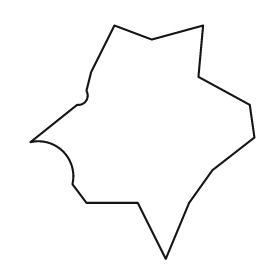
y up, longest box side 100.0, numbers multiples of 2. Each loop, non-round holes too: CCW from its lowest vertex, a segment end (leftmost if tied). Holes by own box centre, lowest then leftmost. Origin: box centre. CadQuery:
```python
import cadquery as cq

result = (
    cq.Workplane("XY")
    .moveTo(10.0, -50.0)
    .lineTo(20.0, -26.0)
    .lineTo(30.0, -12.0)
    .lineTo(48.0, 2.0)
    .lineTo(46.0, 16.0)
    .lineTo(24.0, 28.0)
    .lineTo(26.0, 50.0)
    .lineTo(4.0, 44.0)
    .lineTo(-12.0, 50.0)
    .lineTo(-22.0, 30.0)
    .lineTo(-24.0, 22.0)
    .threePointArc((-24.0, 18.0), (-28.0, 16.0))
    .lineTo(-48.0, 0.0)
    .threePointArc((-34.0, -4.0), (-30.0, -18.0))
    .lineTo(-24.0, -26.0)
    .lineTo(-2.0, -26.0)
    .close()
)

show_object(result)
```